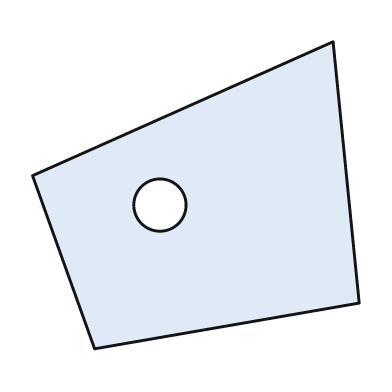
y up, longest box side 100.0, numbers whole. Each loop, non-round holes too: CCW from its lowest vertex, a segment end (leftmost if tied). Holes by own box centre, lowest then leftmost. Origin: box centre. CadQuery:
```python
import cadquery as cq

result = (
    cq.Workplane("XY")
    .moveTo(-31.0, -47.0)
    .lineTo(50.0, -33.0)
    .lineTo(42.0, 47.0)
    .lineTo(-50.0, 6.0)
    .close()
    .moveTo(-11.0, -3.0)
    .circle(8.0)
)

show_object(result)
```